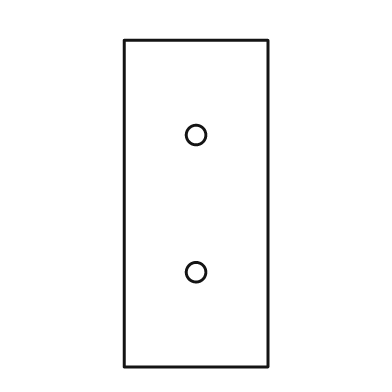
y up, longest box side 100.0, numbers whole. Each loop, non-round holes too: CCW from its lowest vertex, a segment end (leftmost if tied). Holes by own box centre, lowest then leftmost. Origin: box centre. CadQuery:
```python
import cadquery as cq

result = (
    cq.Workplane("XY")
    .moveTo(-22.0, -50.0)
    .lineTo(22.0, -50.0)
    .lineTo(22.0, 50.0)
    .lineTo(-22.0, 50.0)
    .close()
    .moveTo(0.0, -21.0)
    .circle(3.0)
    .moveTo(0.0, 21.0)
    .circle(3.0)
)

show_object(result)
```